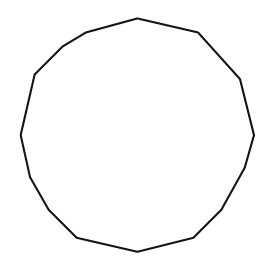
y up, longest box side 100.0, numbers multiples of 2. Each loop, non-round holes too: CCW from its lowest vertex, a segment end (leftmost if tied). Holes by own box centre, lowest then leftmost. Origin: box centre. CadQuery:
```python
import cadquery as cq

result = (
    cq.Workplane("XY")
    .moveTo(0.0, -50.0)
    .lineTo(24.0, -44.0)
    .lineTo(36.0, -32.0)
    .lineTo(46.0, -14.0)
    .lineTo(50.0, 0.0)
    .lineTo(44.0, 24.0)
    .lineTo(26.0, 44.0)
    .lineTo(0.0, 50.0)
    .lineTo(-22.0, 44.0)
    .lineTo(-32.0, 38.0)
    .lineTo(-44.0, 26.0)
    .lineTo(-50.0, 0.0)
    .lineTo(-46.0, -18.0)
    .lineTo(-38.0, -32.0)
    .lineTo(-26.0, -44.0)
    .close()
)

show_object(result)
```